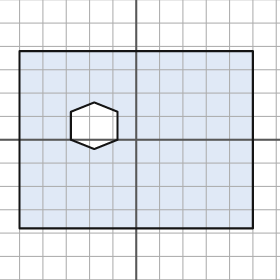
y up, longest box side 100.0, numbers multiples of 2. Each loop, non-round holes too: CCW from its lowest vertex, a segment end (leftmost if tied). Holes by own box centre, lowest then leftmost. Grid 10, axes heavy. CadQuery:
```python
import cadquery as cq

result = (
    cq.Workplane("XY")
    .moveTo(-50.0, -38.0)
    .lineTo(50.0, -38.0)
    .lineTo(50.0, 38.0)
    .lineTo(-50.0, 38.0)
    .close()
    .moveTo(-18.0, -4.0)
    .lineTo(-8.0, 0.0)
    .lineTo(-8.0, 12.0)
    .lineTo(-18.0, 16.0)
    .lineTo(-28.0, 12.0)
    .lineTo(-28.0, 0.0)
    .close()
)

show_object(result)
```